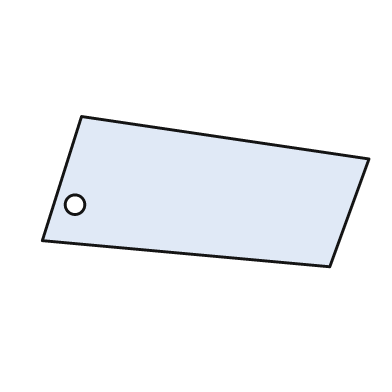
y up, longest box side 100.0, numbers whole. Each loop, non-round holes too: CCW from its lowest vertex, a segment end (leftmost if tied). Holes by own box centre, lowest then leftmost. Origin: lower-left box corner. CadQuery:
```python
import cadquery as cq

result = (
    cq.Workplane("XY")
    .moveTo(88.0, 0.0)
    .lineTo(100.0, 33.0)
    .lineTo(12.0, 46.0)
    .lineTo(0.0, 8.0)
    .close()
    .moveTo(10.0, 19.0)
    .circle(3.0)
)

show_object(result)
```